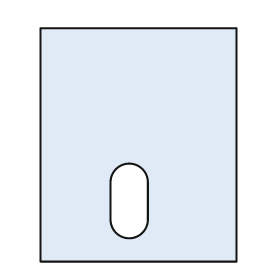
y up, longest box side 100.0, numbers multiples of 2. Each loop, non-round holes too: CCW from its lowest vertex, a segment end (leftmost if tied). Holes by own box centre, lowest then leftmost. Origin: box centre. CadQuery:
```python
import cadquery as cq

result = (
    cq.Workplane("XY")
    .moveTo(-42.0, -50.0)
    .lineTo(42.0, -50.0)
    .lineTo(42.0, 50.0)
    .lineTo(-42.0, 50.0)
    .close()
    .moveTo(-12.0, -32.0)
    .threePointArc((-4.0, -40.0), (4.0, -32.0))
    .lineTo(4.0, -16.0)
    .threePointArc((-4.0, -8.0), (-12.0, -16.0))
    .close()
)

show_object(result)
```